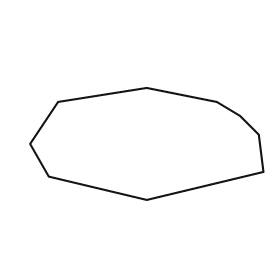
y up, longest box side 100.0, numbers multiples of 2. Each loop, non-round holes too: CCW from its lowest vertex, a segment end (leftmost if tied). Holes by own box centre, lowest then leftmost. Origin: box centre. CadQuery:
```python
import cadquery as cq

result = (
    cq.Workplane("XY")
    .moveTo(0.0, -24.0)
    .lineTo(50.0, -12.0)
    .lineTo(48.0, 4.0)
    .lineTo(40.0, 12.0)
    .lineTo(30.0, 18.0)
    .lineTo(0.0, 24.0)
    .lineTo(-38.0, 18.0)
    .lineTo(-50.0, 0.0)
    .lineTo(-42.0, -14.0)
    .close()
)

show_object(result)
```